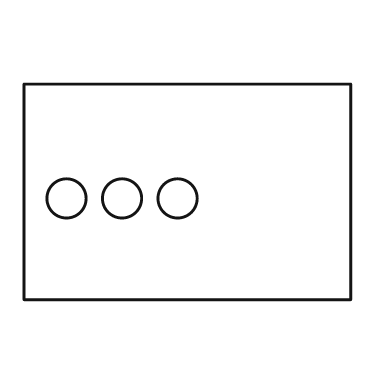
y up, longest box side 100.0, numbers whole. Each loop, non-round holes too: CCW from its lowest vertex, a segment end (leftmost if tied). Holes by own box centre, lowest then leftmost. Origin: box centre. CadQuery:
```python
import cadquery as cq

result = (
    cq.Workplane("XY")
    .moveTo(-50.0, -33.0)
    .lineTo(50.0, -33.0)
    .lineTo(50.0, 33.0)
    .lineTo(-50.0, 33.0)
    .close()
    .moveTo(-37.0, -2.0)
    .circle(6.0)
    .moveTo(-20.0, -2.0)
    .circle(6.0)
    .moveTo(-3.0, -2.0)
    .circle(6.0)
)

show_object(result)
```